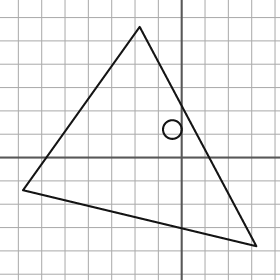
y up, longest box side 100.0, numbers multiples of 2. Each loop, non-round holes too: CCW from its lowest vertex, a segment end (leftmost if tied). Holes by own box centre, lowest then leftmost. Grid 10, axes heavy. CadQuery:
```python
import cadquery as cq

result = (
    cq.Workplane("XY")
    .moveTo(32.0, -38.0)
    .lineTo(-18.0, 56.0)
    .lineTo(-68.0, -14.0)
    .close()
    .moveTo(-4.0, 12.0)
    .circle(4.0)
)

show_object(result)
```